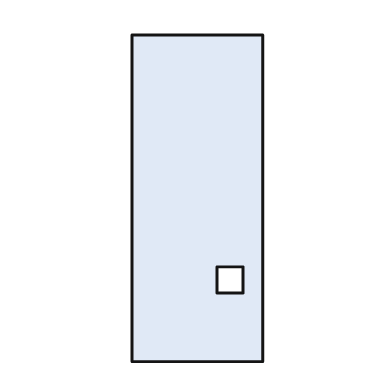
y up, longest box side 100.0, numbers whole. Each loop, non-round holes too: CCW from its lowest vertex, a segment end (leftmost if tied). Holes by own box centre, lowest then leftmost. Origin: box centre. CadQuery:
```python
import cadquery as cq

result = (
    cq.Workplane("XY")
    .moveTo(-20.0, -50.0)
    .lineTo(20.0, -50.0)
    .lineTo(20.0, 50.0)
    .lineTo(-20.0, 50.0)
    .close()
    .moveTo(6.0, -29.0)
    .lineTo(14.0, -29.0)
    .lineTo(14.0, -21.0)
    .lineTo(6.0, -21.0)
    .close()
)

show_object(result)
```